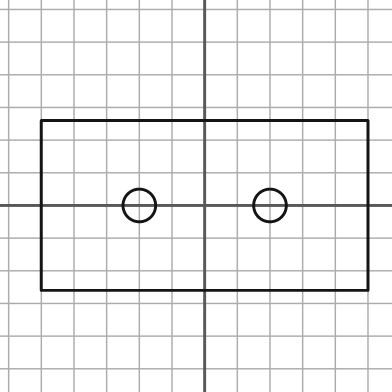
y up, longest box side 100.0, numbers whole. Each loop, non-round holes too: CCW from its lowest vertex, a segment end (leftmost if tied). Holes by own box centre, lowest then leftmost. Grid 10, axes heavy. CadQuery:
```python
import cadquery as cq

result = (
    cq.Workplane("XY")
    .moveTo(-50.0, -26.0)
    .lineTo(50.0, -26.0)
    .lineTo(50.0, 26.0)
    .lineTo(-50.0, 26.0)
    .close()
    .moveTo(-20.0, 0.0)
    .circle(5.0)
    .moveTo(20.0, 0.0)
    .circle(5.0)
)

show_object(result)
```